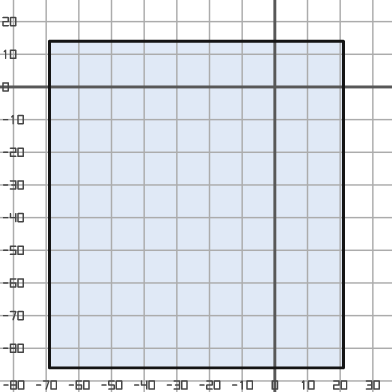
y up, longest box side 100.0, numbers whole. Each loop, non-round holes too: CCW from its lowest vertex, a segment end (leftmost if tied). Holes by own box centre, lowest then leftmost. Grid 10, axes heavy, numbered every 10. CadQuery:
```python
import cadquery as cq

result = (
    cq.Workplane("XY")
    .moveTo(-69.0, -86.0)
    .lineTo(21.0, -86.0)
    .lineTo(21.0, 14.0)
    .lineTo(-69.0, 14.0)
    .close()
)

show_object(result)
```